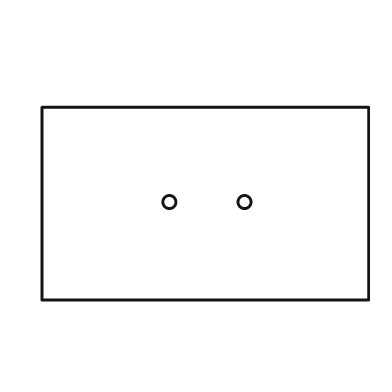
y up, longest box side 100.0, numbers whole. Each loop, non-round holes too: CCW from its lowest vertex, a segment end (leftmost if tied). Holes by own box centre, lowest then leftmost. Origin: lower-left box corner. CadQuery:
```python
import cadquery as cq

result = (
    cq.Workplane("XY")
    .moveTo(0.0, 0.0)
    .lineTo(100.0, 0.0)
    .lineTo(100.0, 59.0)
    .lineTo(0.0, 59.0)
    .close()
    .moveTo(39.0, 30.0)
    .circle(2.0)
    .moveTo(62.0, 30.0)
    .circle(2.0)
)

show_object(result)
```